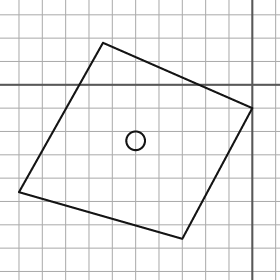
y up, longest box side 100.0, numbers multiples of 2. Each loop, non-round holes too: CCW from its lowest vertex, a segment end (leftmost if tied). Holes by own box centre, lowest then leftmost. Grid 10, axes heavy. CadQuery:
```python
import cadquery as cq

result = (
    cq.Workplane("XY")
    .moveTo(-30.0, -66.0)
    .lineTo(0.0, -10.0)
    .lineTo(-64.0, 18.0)
    .lineTo(-100.0, -46.0)
    .close()
    .moveTo(-50.0, -24.0)
    .circle(4.0)
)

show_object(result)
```